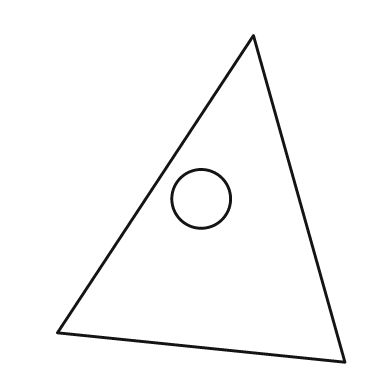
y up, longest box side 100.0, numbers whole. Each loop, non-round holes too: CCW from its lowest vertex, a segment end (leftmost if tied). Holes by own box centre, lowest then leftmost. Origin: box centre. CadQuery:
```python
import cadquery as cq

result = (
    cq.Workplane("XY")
    .moveTo(44.0, -50.0)
    .lineTo(16.0, 50.0)
    .lineTo(-44.0, -41.0)
    .close()
    .moveTo(0.0, 0.0)
    .circle(9.0)
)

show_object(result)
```